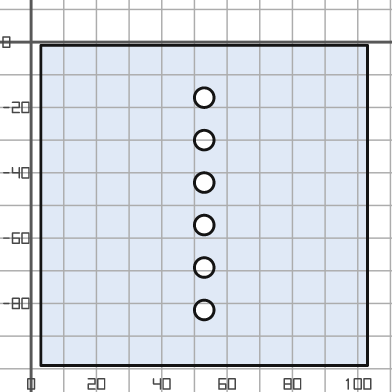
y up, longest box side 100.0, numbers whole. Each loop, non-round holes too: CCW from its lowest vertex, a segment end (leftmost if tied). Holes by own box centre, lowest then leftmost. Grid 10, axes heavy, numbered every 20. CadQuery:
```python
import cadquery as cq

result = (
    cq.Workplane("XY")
    .moveTo(3.0, -99.0)
    .lineTo(103.0, -99.0)
    .lineTo(103.0, -1.0)
    .lineTo(3.0, -1.0)
    .close()
    .moveTo(53.0, -82.0)
    .circle(3.0)
    .moveTo(53.0, -69.0)
    .circle(3.0)
    .moveTo(53.0, -56.0)
    .circle(3.0)
    .moveTo(53.0, -43.0)
    .circle(3.0)
    .moveTo(53.0, -30.0)
    .circle(3.0)
    .moveTo(53.0, -17.0)
    .circle(3.0)
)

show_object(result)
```